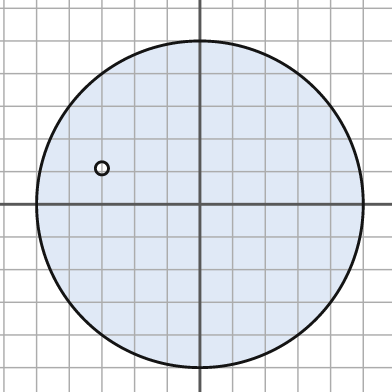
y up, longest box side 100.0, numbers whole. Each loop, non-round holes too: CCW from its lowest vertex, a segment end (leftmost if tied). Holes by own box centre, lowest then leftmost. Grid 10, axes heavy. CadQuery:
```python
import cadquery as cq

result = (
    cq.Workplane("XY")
    .moveTo(0.0, 0.0)
    .circle(50.0)
    .moveTo(-30.0, 11.0)
    .circle(2.0)
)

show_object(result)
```